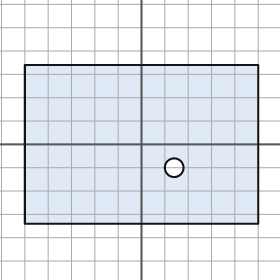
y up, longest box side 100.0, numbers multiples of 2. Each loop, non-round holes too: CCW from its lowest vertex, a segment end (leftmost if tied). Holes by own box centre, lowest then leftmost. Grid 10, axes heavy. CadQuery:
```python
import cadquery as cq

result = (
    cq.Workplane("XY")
    .moveTo(-50.0, -34.0)
    .lineTo(50.0, -34.0)
    .lineTo(50.0, 34.0)
    .lineTo(-50.0, 34.0)
    .close()
    .moveTo(14.0, -10.0)
    .circle(4.0)
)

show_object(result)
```